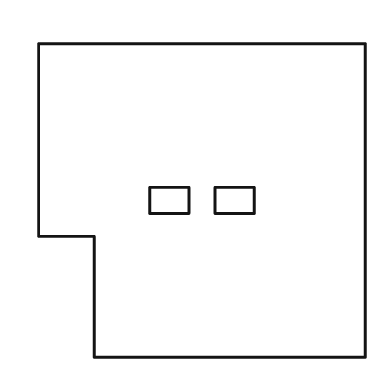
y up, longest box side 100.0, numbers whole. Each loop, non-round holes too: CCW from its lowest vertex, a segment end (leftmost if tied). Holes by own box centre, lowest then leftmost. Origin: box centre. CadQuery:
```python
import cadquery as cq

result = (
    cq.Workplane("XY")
    .moveTo(-33.0, -48.0)
    .lineTo(50.0, -48.0)
    .lineTo(50.0, 48.0)
    .lineTo(-50.0, 48.0)
    .lineTo(-50.0, -11.0)
    .lineTo(-33.0, -11.0)
    .close()
    .moveTo(-16.0, -4.0)
    .lineTo(-4.0, -4.0)
    .lineTo(-4.0, 4.0)
    .lineTo(-16.0, 4.0)
    .close()
    .moveTo(4.0, -4.0)
    .lineTo(16.0, -4.0)
    .lineTo(16.0, 4.0)
    .lineTo(4.0, 4.0)
    .close()
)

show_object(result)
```